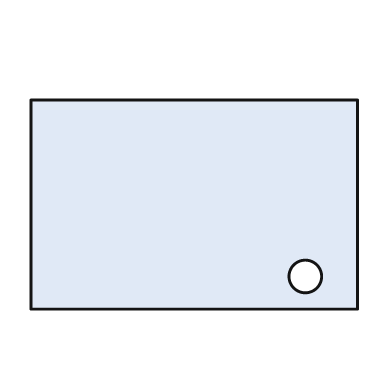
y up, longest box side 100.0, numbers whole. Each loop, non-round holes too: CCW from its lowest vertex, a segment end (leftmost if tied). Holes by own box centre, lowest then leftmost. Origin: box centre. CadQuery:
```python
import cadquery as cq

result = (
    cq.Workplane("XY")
    .moveTo(-50.0, -32.0)
    .lineTo(50.0, -32.0)
    .lineTo(50.0, 32.0)
    .lineTo(-50.0, 32.0)
    .close()
    .moveTo(34.0, -22.0)
    .circle(5.0)
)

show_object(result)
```